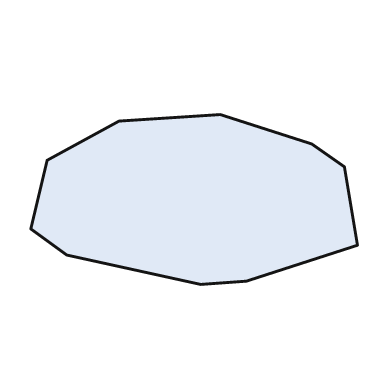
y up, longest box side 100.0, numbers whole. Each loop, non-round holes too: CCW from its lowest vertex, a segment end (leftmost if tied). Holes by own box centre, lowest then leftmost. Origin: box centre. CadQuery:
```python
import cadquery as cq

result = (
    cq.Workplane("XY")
    .moveTo(2.0, -26.0)
    .lineTo(16.0, -25.0)
    .lineTo(50.0, -14.0)
    .lineTo(46.0, 10.0)
    .lineTo(36.0, 17.0)
    .lineTo(8.0, 26.0)
    .lineTo(-23.0, 24.0)
    .lineTo(-45.0, 12.0)
    .lineTo(-50.0, -9.0)
    .lineTo(-39.0, -17.0)
    .close()
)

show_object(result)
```